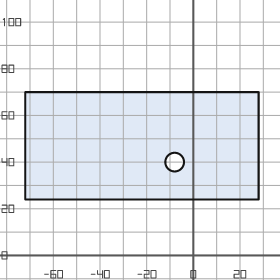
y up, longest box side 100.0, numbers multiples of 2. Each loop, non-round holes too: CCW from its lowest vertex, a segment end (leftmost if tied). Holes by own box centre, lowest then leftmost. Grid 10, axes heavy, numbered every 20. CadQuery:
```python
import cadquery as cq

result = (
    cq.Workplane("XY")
    .moveTo(-72.0, 24.0)
    .lineTo(28.0, 24.0)
    .lineTo(28.0, 70.0)
    .lineTo(-72.0, 70.0)
    .close()
    .moveTo(-8.0, 40.0)
    .circle(4.0)
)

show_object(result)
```